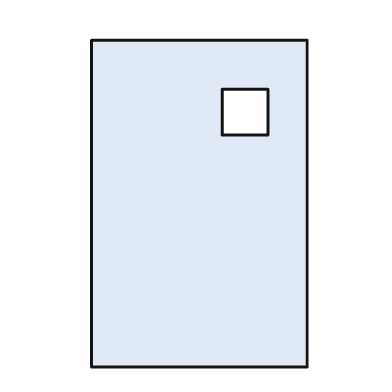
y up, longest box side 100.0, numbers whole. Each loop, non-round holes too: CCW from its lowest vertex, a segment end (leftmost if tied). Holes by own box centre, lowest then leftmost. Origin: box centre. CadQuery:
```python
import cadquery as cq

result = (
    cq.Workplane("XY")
    .moveTo(-33.0, -50.0)
    .lineTo(33.0, -50.0)
    .lineTo(33.0, 50.0)
    .lineTo(-33.0, 50.0)
    .close()
    .moveTo(7.0, 21.0)
    .lineTo(21.0, 21.0)
    .lineTo(21.0, 35.0)
    .lineTo(7.0, 35.0)
    .close()
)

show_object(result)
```